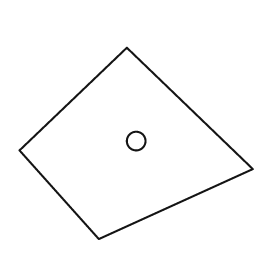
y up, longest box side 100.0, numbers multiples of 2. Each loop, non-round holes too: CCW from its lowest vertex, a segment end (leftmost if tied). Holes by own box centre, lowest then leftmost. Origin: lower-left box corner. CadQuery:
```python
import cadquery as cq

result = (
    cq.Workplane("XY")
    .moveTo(34.0, 0.0)
    .lineTo(100.0, 30.0)
    .lineTo(46.0, 82.0)
    .lineTo(0.0, 38.0)
    .close()
    .moveTo(50.0, 42.0)
    .circle(4.0)
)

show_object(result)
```